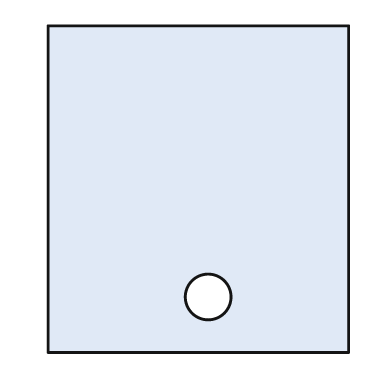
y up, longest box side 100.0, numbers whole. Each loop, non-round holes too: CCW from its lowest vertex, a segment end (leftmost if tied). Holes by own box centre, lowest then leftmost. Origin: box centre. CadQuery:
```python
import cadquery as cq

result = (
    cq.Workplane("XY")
    .moveTo(-46.0, -50.0)
    .lineTo(46.0, -50.0)
    .lineTo(46.0, 50.0)
    .lineTo(-46.0, 50.0)
    .close()
    .moveTo(3.0, -33.0)
    .circle(7.0)
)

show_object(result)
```